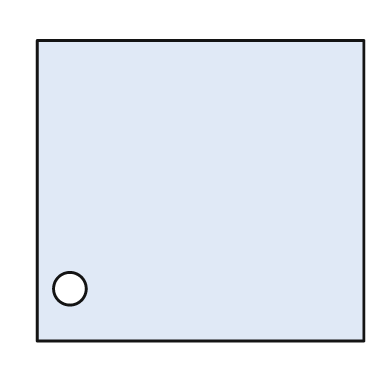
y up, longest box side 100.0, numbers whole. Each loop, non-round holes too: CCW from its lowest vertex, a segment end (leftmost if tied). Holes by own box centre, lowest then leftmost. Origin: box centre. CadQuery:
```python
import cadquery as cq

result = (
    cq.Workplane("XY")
    .moveTo(-50.0, -46.0)
    .lineTo(50.0, -46.0)
    .lineTo(50.0, 46.0)
    .lineTo(-50.0, 46.0)
    .close()
    .moveTo(-40.0, -30.0)
    .circle(5.0)
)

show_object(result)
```